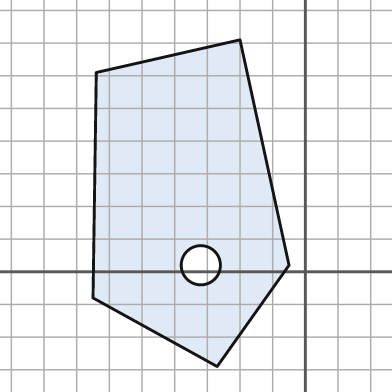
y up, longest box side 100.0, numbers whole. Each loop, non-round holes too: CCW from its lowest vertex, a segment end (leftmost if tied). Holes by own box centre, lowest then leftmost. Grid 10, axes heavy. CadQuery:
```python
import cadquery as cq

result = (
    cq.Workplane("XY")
    .moveTo(-27.0, -29.0)
    .lineTo(-5.0, 2.0)
    .lineTo(-20.0, 71.0)
    .lineTo(-64.0, 61.0)
    .lineTo(-65.0, -8.0)
    .close()
    .moveTo(-32.0, 2.0)
    .circle(6.0)
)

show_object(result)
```